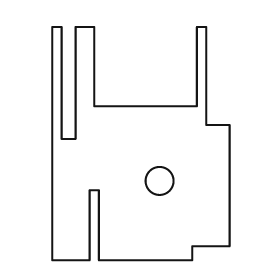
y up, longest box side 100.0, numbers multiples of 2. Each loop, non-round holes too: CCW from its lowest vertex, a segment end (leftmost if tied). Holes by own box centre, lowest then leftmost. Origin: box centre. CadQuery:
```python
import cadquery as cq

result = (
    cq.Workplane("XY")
    .moveTo(-38.0, -50.0)
    .lineTo(-22.0, -50.0)
    .lineTo(-22.0, -20.0)
    .lineTo(-18.0, -20.0)
    .lineTo(-18.0, -50.0)
    .lineTo(22.0, -50.0)
    .lineTo(22.0, -44.0)
    .lineTo(38.0, -44.0)
    .lineTo(38.0, 8.0)
    .lineTo(28.0, 8.0)
    .lineTo(28.0, 50.0)
    .lineTo(24.0, 50.0)
    .lineTo(24.0, 16.0)
    .lineTo(-20.0, 16.0)
    .lineTo(-20.0, 50.0)
    .lineTo(-28.0, 50.0)
    .lineTo(-28.0, 2.0)
    .lineTo(-34.0, 2.0)
    .lineTo(-34.0, 50.0)
    .lineTo(-38.0, 50.0)
    .close()
    .moveTo(8.0, -16.0)
    .circle(6.0)
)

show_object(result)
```